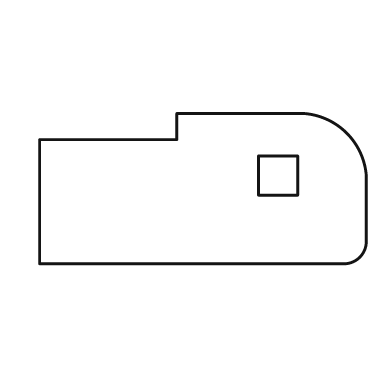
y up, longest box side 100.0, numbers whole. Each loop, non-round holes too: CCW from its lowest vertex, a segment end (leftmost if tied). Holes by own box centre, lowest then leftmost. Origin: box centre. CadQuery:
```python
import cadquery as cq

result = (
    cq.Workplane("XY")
    .moveTo(-50.0, -23.0)
    .lineTo(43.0, -23.0)
    .threePointArc((48.0, -21.0), (50.0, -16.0))
    .lineTo(50.0, 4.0)
    .threePointArc((44.0, 17.0), (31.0, 23.0))
    .lineTo(-8.0, 23.0)
    .lineTo(-8.0, 15.0)
    .lineTo(-50.0, 15.0)
    .close()
    .moveTo(17.0, -2.0)
    .lineTo(29.0, -2.0)
    .lineTo(29.0, 10.0)
    .lineTo(17.0, 10.0)
    .close()
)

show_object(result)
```